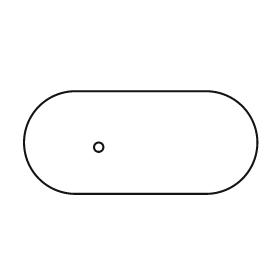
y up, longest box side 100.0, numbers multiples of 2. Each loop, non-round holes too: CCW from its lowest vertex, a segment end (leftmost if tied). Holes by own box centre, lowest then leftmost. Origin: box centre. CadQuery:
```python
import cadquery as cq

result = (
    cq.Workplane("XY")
    .moveTo(-28.0, -22.0)
    .lineTo(28.0, -22.0)
    .threePointArc((50.0, 0.0), (28.0, 22.0))
    .lineTo(-28.0, 22.0)
    .threePointArc((-50.0, 0.0), (-28.0, -22.0))
    .close()
    .moveTo(-18.0, -2.0)
    .circle(2.0)
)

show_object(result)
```